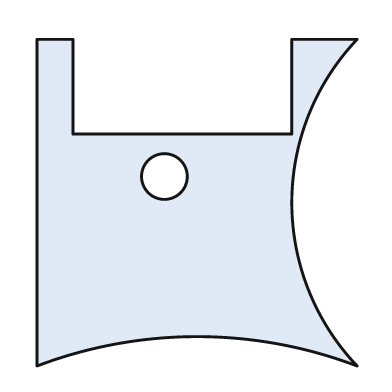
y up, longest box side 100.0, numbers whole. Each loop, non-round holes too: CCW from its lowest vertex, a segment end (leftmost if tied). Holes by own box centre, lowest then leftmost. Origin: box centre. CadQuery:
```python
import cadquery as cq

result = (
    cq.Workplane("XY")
    .moveTo(-49.0, -50.0)
    .threePointArc((0.0, -41.0), (49.0, -50.0))
    .threePointArc((29.0, 0.0), (49.0, 50.0))
    .lineTo(29.0, 50.0)
    .lineTo(29.0, 21.0)
    .lineTo(-38.0, 21.0)
    .lineTo(-38.0, 50.0)
    .lineTo(-49.0, 50.0)
    .close()
    .moveTo(-10.0, 8.0)
    .circle(7.0)
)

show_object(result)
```